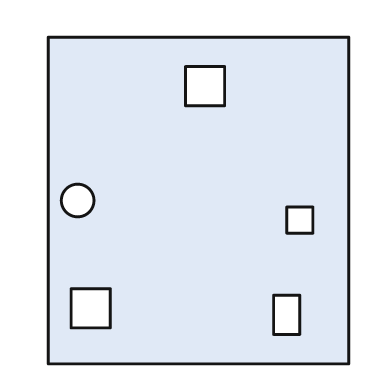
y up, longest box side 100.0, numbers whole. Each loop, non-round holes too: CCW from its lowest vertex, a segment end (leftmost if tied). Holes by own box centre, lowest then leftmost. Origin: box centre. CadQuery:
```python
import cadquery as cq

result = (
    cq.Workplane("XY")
    .moveTo(-46.0, -50.0)
    .lineTo(46.0, -50.0)
    .lineTo(46.0, 50.0)
    .lineTo(-46.0, 50.0)
    .close()
    .moveTo(23.0, -41.0)
    .lineTo(31.0, -41.0)
    .lineTo(31.0, -29.0)
    .lineTo(23.0, -29.0)
    .close()
    .moveTo(-39.0, -39.0)
    .lineTo(-27.0, -39.0)
    .lineTo(-27.0, -27.0)
    .lineTo(-39.0, -27.0)
    .close()
    .moveTo(27.0, -10.0)
    .lineTo(35.0, -10.0)
    .lineTo(35.0, -2.0)
    .lineTo(27.0, -2.0)
    .close()
    .moveTo(-37.0, 0.0)
    .circle(5.0)
    .moveTo(-4.0, 29.0)
    .lineTo(8.0, 29.0)
    .lineTo(8.0, 41.0)
    .lineTo(-4.0, 41.0)
    .close()
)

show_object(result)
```